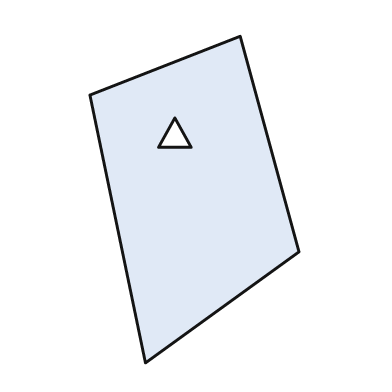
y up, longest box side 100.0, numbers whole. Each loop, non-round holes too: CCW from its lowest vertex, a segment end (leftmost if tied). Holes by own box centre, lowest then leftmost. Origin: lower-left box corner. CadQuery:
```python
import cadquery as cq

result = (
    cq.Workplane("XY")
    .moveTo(17.0, 0.0)
    .lineTo(64.0, 34.0)
    .lineTo(46.0, 100.0)
    .lineTo(0.0, 82.0)
    .close()
    .moveTo(21.0, 66.0)
    .lineTo(31.0, 66.0)
    .lineTo(26.0, 75.0)
    .close()
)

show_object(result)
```